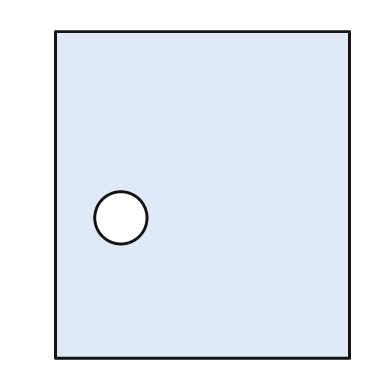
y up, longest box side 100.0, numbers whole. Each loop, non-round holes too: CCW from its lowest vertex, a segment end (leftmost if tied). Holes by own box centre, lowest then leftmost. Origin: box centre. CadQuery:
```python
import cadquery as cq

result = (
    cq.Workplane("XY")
    .moveTo(-45.0, -50.0)
    .lineTo(45.0, -50.0)
    .lineTo(45.0, 50.0)
    .lineTo(-45.0, 50.0)
    .close()
    .moveTo(-25.0, -7.0)
    .circle(8.0)
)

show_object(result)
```